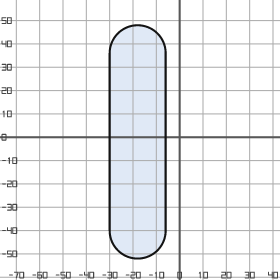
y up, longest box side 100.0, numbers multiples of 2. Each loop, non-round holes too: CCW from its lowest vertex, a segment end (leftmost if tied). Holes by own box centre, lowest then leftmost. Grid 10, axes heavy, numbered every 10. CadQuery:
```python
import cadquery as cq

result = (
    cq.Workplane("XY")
    .moveTo(-30.0, -40.0)
    .threePointArc((-18.0, -52.0), (-6.0, -40.0))
    .lineTo(-6.0, 36.0)
    .threePointArc((-18.0, 48.0), (-30.0, 36.0))
    .close()
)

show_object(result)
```